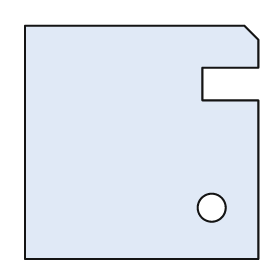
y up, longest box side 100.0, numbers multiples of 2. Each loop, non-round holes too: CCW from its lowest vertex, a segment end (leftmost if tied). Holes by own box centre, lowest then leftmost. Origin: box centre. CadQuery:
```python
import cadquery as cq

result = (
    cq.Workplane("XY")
    .moveTo(-50.0, -50.0)
    .lineTo(50.0, -50.0)
    .lineTo(50.0, 18.0)
    .lineTo(26.0, 18.0)
    .lineTo(26.0, 32.0)
    .lineTo(50.0, 32.0)
    .lineTo(50.0, 44.0)
    .lineTo(44.0, 50.0)
    .lineTo(-50.0, 50.0)
    .close()
    .moveTo(30.0, -28.0)
    .circle(6.0)
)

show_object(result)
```